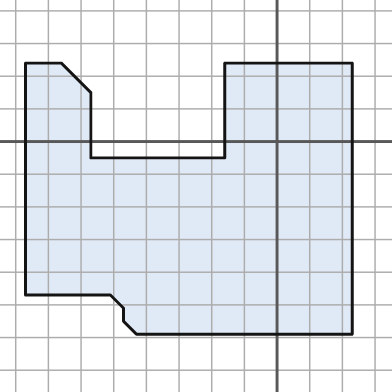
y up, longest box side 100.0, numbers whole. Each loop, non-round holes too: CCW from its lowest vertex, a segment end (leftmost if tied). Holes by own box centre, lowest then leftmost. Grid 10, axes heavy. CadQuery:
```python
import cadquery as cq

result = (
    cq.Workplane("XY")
    .moveTo(-43.0, -59.0)
    .lineTo(23.0, -59.0)
    .lineTo(23.0, 24.0)
    .lineTo(-16.0, 24.0)
    .lineTo(-16.0, -5.0)
    .lineTo(-57.0, -5.0)
    .lineTo(-57.0, 15.0)
    .lineTo(-66.0, 24.0)
    .lineTo(-77.0, 24.0)
    .lineTo(-77.0, -47.0)
    .lineTo(-51.0, -47.0)
    .lineTo(-47.0, -51.0)
    .lineTo(-47.0, -55.0)
    .close()
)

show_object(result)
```